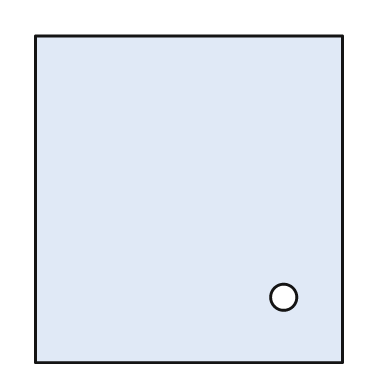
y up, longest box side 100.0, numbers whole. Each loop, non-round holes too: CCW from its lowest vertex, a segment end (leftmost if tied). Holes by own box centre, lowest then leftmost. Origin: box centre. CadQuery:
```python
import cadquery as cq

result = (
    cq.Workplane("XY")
    .moveTo(-47.0, -50.0)
    .lineTo(47.0, -50.0)
    .lineTo(47.0, 50.0)
    .lineTo(-47.0, 50.0)
    .close()
    .moveTo(29.0, -30.0)
    .circle(4.0)
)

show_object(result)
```